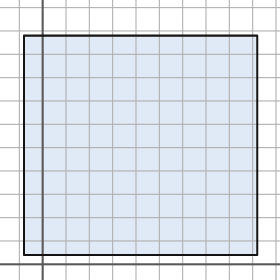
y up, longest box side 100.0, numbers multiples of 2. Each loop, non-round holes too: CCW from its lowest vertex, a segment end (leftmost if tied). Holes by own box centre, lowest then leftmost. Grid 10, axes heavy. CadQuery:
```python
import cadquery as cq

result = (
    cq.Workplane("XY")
    .moveTo(-8.0, 4.0)
    .lineTo(92.0, 4.0)
    .lineTo(92.0, 98.0)
    .lineTo(-8.0, 98.0)
    .close()
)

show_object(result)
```